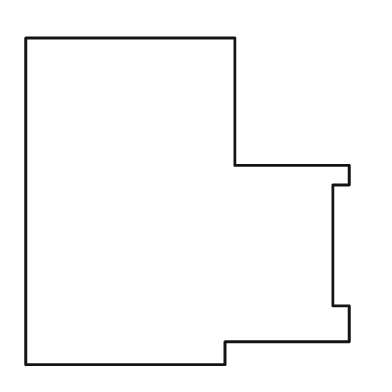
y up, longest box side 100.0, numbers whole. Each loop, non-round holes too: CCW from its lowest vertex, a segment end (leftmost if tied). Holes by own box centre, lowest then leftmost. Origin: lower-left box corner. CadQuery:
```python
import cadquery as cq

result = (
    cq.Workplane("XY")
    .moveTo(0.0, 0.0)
    .lineTo(61.0, 0.0)
    .lineTo(61.0, 7.0)
    .lineTo(99.0, 7.0)
    .lineTo(99.0, 18.0)
    .lineTo(94.0, 18.0)
    .lineTo(94.0, 55.0)
    .lineTo(99.0, 55.0)
    .lineTo(99.0, 61.0)
    .lineTo(64.0, 61.0)
    .lineTo(64.0, 100.0)
    .lineTo(0.0, 100.0)
    .close()
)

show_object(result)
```